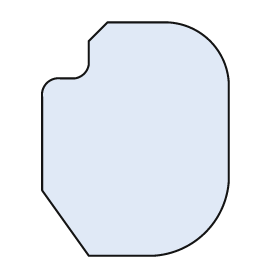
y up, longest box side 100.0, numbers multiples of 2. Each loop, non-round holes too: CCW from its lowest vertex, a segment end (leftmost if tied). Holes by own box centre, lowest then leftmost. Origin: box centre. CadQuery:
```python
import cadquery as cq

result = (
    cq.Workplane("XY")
    .moveTo(-20.0, -50.0)
    .lineTo(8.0, -50.0)
    .threePointArc((30.0, -40.0), (40.0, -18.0))
    .lineTo(40.0, 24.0)
    .threePointArc((32.0, 42.0), (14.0, 50.0))
    .lineTo(-12.0, 50.0)
    .lineTo(-20.0, 42.0)
    .lineTo(-20.0, 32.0)
    .threePointArc((-22.0, 28.0), (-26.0, 26.0))
    .lineTo(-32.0, 26.0)
    .threePointArc((-38.0, 24.0), (-40.0, 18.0))
    .lineTo(-40.0, -22.0)
    .close()
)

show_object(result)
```